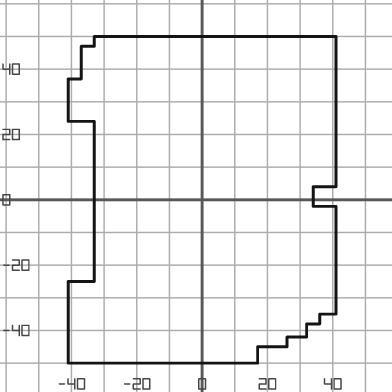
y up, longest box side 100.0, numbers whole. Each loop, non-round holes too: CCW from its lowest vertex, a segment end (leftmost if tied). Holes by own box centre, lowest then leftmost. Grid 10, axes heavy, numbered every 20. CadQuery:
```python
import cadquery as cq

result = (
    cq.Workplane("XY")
    .moveTo(-41.0, -50.0)
    .lineTo(17.0, -50.0)
    .lineTo(17.0, -45.0)
    .lineTo(26.0, -45.0)
    .lineTo(26.0, -42.0)
    .lineTo(32.0, -42.0)
    .lineTo(32.0, -38.0)
    .lineTo(36.0, -38.0)
    .lineTo(36.0, -35.0)
    .lineTo(41.0, -35.0)
    .lineTo(41.0, -2.0)
    .lineTo(34.0, -2.0)
    .lineTo(34.0, 4.0)
    .lineTo(41.0, 4.0)
    .lineTo(41.0, 50.0)
    .lineTo(-33.0, 50.0)
    .lineTo(-33.0, 47.0)
    .lineTo(-37.0, 47.0)
    .lineTo(-37.0, 37.0)
    .lineTo(-41.0, 37.0)
    .lineTo(-41.0, 24.0)
    .lineTo(-33.0, 24.0)
    .lineTo(-33.0, -25.0)
    .lineTo(-41.0, -25.0)
    .close()
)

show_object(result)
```